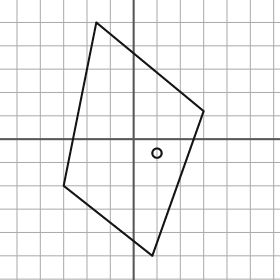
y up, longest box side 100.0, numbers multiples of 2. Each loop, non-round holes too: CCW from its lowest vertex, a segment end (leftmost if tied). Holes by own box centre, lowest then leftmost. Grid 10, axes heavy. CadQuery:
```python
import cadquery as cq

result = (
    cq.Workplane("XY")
    .moveTo(8.0, -50.0)
    .lineTo(30.0, 12.0)
    .lineTo(-16.0, 50.0)
    .lineTo(-30.0, -20.0)
    .close()
    .moveTo(10.0, -6.0)
    .circle(2.0)
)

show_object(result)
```